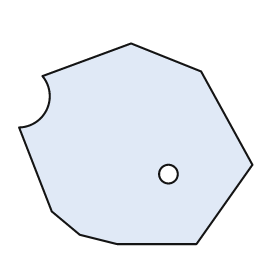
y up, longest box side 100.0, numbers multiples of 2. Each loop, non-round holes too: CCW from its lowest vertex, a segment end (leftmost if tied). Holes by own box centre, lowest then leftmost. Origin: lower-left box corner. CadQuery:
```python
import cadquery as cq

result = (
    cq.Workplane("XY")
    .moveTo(42.0, 0.0)
    .lineTo(76.0, 0.0)
    .lineTo(100.0, 34.0)
    .lineTo(78.0, 74.0)
    .lineTo(48.0, 86.0)
    .lineTo(10.0, 72.0)
    .threePointArc((12.0, 58.0), (0.0, 50.0))
    .lineTo(14.0, 14.0)
    .lineTo(26.0, 4.0)
    .close()
    .moveTo(64.0, 30.0)
    .circle(4.0)
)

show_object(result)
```